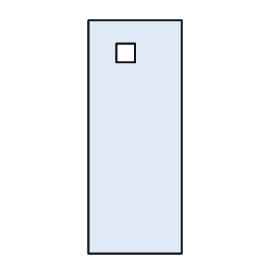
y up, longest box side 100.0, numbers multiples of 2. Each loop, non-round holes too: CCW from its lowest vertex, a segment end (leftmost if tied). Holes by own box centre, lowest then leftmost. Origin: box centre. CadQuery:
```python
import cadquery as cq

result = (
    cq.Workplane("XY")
    .moveTo(-20.0, -50.0)
    .lineTo(20.0, -50.0)
    .lineTo(20.0, 50.0)
    .lineTo(-20.0, 50.0)
    .close()
    .moveTo(-8.0, 32.0)
    .lineTo(0.0, 32.0)
    .lineTo(0.0, 40.0)
    .lineTo(-8.0, 40.0)
    .close()
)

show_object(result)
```